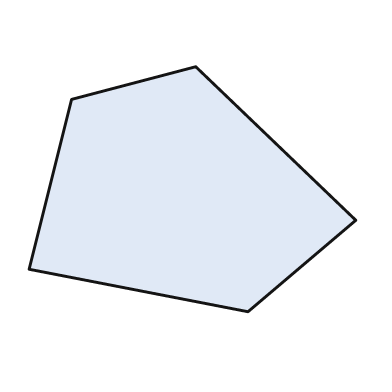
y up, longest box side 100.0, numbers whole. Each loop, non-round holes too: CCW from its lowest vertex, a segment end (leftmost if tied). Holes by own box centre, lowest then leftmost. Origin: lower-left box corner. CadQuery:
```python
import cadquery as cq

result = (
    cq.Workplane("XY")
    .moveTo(67.0, 0.0)
    .lineTo(100.0, 28.0)
    .lineTo(51.0, 75.0)
    .lineTo(13.0, 65.0)
    .lineTo(0.0, 13.0)
    .close()
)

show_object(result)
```